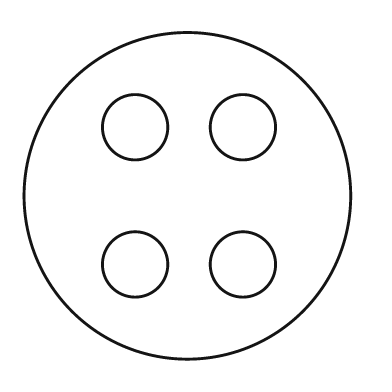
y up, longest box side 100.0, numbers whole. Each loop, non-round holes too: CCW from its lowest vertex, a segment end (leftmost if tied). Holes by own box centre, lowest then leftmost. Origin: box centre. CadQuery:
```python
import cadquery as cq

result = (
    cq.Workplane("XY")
    .moveTo(0.0, 0.0)
    .circle(50.0)
    .moveTo(-16.0, -21.0)
    .circle(10.0)
    .moveTo(17.0, -21.0)
    .circle(10.0)
    .moveTo(-16.0, 21.0)
    .circle(10.0)
    .moveTo(17.0, 21.0)
    .circle(10.0)
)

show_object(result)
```